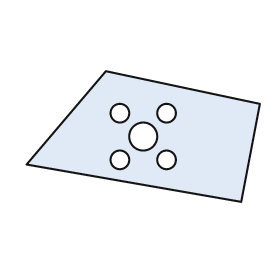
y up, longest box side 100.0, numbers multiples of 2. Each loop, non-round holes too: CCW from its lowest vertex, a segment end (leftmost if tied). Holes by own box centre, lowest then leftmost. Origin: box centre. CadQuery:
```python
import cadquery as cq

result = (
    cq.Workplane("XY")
    .moveTo(42.0, -28.0)
    .lineTo(50.0, 14.0)
    .lineTo(-16.0, 28.0)
    .lineTo(-50.0, -12.0)
    .close()
    .moveTo(-10.0, -10.0)
    .circle(4.0)
    .moveTo(10.0, -10.0)
    .circle(4.0)
    .moveTo(0.0, 0.0)
    .circle(6.0)
    .moveTo(-10.0, 10.0)
    .circle(4.0)
    .moveTo(10.0, 10.0)
    .circle(4.0)
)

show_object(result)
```